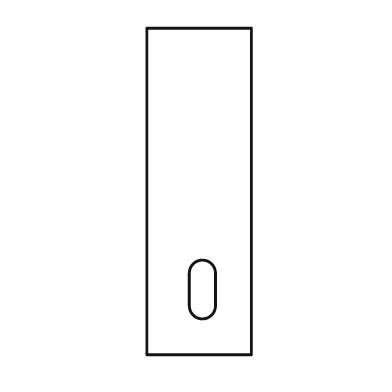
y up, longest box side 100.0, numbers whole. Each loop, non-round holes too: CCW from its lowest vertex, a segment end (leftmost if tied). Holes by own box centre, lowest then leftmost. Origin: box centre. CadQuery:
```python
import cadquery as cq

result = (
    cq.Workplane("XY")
    .moveTo(-16.0, -50.0)
    .lineTo(16.0, -50.0)
    .lineTo(16.0, 50.0)
    .lineTo(-16.0, 50.0)
    .close()
    .moveTo(-3.0, -35.0)
    .threePointArc((1.0, -39.0), (5.0, -35.0))
    .lineTo(5.0, -25.0)
    .threePointArc((1.0, -21.0), (-3.0, -25.0))
    .close()
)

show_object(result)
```